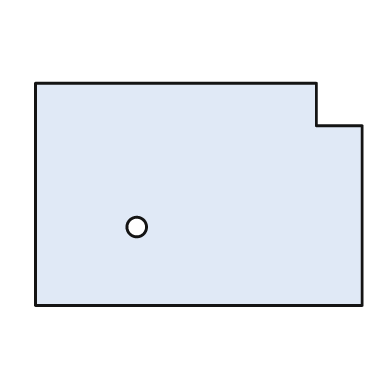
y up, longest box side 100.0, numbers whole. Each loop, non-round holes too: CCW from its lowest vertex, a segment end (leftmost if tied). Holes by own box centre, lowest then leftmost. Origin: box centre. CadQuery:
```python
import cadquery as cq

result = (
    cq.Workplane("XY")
    .moveTo(-50.0, -34.0)
    .lineTo(50.0, -34.0)
    .lineTo(50.0, 21.0)
    .lineTo(36.0, 21.0)
    .lineTo(36.0, 34.0)
    .lineTo(-50.0, 34.0)
    .close()
    .moveTo(-19.0, -10.0)
    .circle(3.0)
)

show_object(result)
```